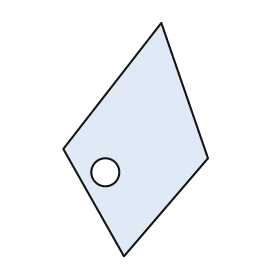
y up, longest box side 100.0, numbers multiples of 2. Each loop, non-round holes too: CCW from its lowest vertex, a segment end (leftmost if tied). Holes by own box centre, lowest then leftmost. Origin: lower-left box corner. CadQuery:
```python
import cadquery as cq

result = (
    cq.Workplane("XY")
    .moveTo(26.0, 0.0)
    .lineTo(62.0, 42.0)
    .lineTo(42.0, 100.0)
    .lineTo(0.0, 46.0)
    .close()
    .moveTo(18.0, 36.0)
    .circle(6.0)
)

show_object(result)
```